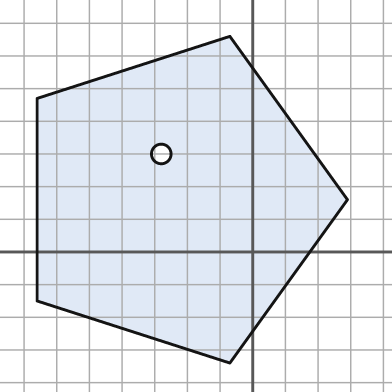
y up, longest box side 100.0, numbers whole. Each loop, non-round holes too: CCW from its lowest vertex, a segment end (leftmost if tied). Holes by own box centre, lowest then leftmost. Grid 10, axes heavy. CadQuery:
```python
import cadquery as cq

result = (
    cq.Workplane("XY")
    .moveTo(-7.0, -34.0)
    .lineTo(29.0, 16.0)
    .lineTo(-7.0, 66.0)
    .lineTo(-66.0, 47.0)
    .lineTo(-66.0, -15.0)
    .close()
    .moveTo(-28.0, 30.0)
    .circle(3.0)
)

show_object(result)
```